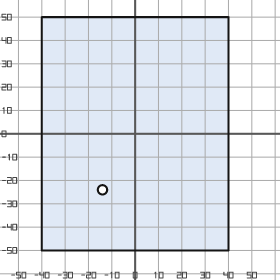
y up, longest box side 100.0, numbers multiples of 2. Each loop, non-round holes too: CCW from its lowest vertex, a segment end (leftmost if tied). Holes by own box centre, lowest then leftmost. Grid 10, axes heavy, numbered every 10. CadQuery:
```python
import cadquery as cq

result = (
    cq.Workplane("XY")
    .moveTo(-40.0, -50.0)
    .lineTo(40.0, -50.0)
    .lineTo(40.0, 50.0)
    .lineTo(-40.0, 50.0)
    .close()
    .moveTo(-14.0, -24.0)
    .circle(2.0)
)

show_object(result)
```